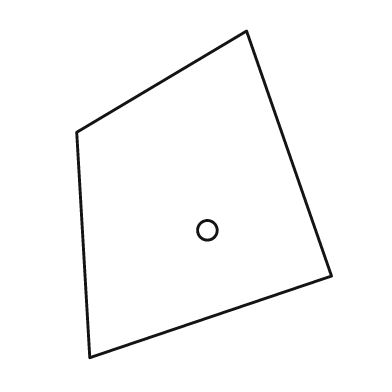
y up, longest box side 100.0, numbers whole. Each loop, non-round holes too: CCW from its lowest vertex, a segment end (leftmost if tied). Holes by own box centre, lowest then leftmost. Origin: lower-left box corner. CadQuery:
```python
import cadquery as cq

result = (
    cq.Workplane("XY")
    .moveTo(4.0, 0.0)
    .lineTo(78.0, 25.0)
    .lineTo(52.0, 100.0)
    .lineTo(0.0, 69.0)
    .close()
    .moveTo(40.0, 39.0)
    .circle(3.0)
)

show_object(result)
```